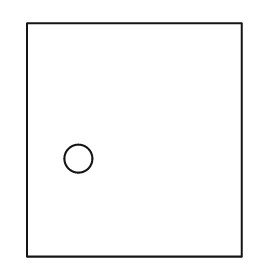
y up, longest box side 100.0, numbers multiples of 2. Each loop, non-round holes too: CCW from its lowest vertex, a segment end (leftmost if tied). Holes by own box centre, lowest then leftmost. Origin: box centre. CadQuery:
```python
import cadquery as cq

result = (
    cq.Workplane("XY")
    .moveTo(-46.0, -50.0)
    .lineTo(46.0, -50.0)
    .lineTo(46.0, 50.0)
    .lineTo(-46.0, 50.0)
    .close()
    .moveTo(-24.0, -8.0)
    .circle(6.0)
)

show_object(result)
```